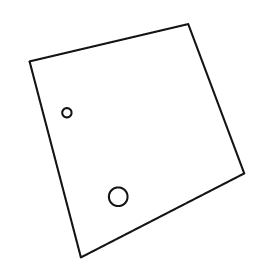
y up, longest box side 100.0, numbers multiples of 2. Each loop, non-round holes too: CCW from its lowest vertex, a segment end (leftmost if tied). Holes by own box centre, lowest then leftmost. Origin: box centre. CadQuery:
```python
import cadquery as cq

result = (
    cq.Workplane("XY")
    .moveTo(-24.0, -50.0)
    .lineTo(46.0, -14.0)
    .lineTo(22.0, 50.0)
    .lineTo(-46.0, 34.0)
    .close()
    .moveTo(-8.0, -24.0)
    .circle(4.0)
    .moveTo(-30.0, 12.0)
    .circle(2.0)
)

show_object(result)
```